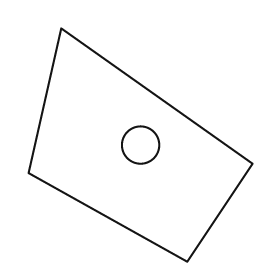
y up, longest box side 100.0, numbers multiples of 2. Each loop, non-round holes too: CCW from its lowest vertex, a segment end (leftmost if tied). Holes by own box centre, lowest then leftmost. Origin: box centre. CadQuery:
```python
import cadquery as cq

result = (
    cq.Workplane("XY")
    .moveTo(20.0, -50.0)
    .lineTo(48.0, -8.0)
    .lineTo(-34.0, 50.0)
    .lineTo(-48.0, -12.0)
    .close()
    .moveTo(0.0, 0.0)
    .circle(8.0)
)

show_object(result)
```